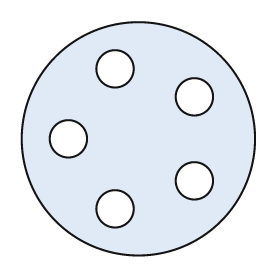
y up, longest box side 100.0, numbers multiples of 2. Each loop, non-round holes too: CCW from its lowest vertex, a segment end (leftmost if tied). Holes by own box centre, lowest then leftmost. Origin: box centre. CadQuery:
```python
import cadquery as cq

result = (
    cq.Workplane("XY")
    .moveTo(0.0, 0.0)
    .circle(50.0)
    .moveTo(-10.0, -30.0)
    .circle(8.0)
    .moveTo(24.0, -18.0)
    .circle(8.0)
    .moveTo(-30.0, 0.0)
    .circle(8.0)
    .moveTo(24.0, 18.0)
    .circle(8.0)
    .moveTo(-10.0, 30.0)
    .circle(8.0)
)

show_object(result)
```